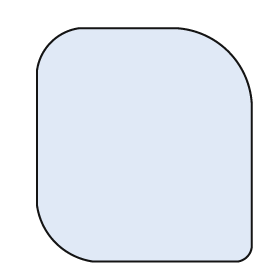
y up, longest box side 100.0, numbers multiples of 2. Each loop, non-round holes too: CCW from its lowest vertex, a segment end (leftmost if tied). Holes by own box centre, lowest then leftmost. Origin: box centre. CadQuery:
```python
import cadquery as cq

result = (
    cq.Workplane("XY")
    .moveTo(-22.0, -50.0)
    .lineTo(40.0, -50.0)
    .threePointArc((44.0, -48.0), (46.0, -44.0))
    .lineTo(46.0, 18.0)
    .threePointArc((36.0, 40.0), (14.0, 50.0))
    .lineTo(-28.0, 50.0)
    .threePointArc((-40.0, 44.0), (-46.0, 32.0))
    .lineTo(-46.0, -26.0)
    .threePointArc((-38.0, -42.0), (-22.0, -50.0))
    .close()
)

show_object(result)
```